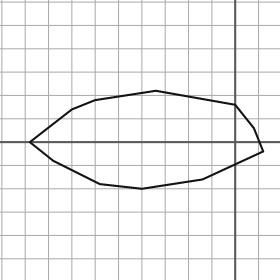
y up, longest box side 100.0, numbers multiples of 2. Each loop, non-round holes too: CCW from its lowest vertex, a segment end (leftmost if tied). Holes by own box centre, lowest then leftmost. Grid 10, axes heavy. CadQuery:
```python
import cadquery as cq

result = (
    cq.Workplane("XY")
    .moveTo(-40.0, -20.0)
    .lineTo(-14.0, -16.0)
    .lineTo(12.0, -4.0)
    .lineTo(8.0, 6.0)
    .lineTo(0.0, 16.0)
    .lineTo(-34.0, 22.0)
    .lineTo(-60.0, 18.0)
    .lineTo(-70.0, 14.0)
    .lineTo(-88.0, 0.0)
    .lineTo(-78.0, -8.0)
    .lineTo(-58.0, -18.0)
    .close()
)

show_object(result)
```